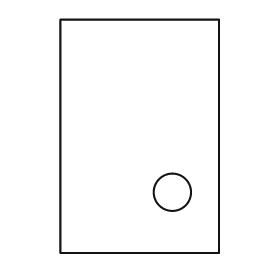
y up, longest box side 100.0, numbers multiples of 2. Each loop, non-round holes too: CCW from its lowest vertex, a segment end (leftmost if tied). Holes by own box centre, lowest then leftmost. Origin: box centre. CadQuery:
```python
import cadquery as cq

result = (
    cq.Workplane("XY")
    .moveTo(-34.0, -50.0)
    .lineTo(34.0, -50.0)
    .lineTo(34.0, 50.0)
    .lineTo(-34.0, 50.0)
    .close()
    .moveTo(14.0, -24.0)
    .circle(8.0)
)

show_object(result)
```